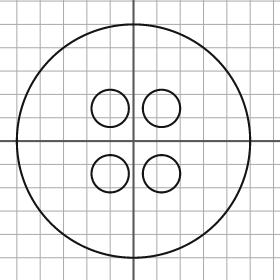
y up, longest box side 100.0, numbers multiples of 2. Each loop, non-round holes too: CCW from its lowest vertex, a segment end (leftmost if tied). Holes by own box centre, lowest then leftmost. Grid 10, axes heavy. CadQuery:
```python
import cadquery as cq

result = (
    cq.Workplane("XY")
    .moveTo(0.0, 0.0)
    .circle(50.0)
    .moveTo(-10.0, -14.0)
    .circle(8.0)
    .moveTo(12.0, -14.0)
    .circle(8.0)
    .moveTo(-10.0, 14.0)
    .circle(8.0)
    .moveTo(12.0, 14.0)
    .circle(8.0)
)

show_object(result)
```